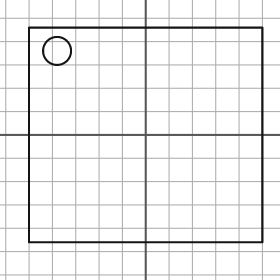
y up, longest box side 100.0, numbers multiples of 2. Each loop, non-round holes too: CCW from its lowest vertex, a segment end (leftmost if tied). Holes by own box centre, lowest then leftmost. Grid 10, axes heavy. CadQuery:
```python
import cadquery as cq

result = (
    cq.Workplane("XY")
    .moveTo(-50.0, -46.0)
    .lineTo(50.0, -46.0)
    .lineTo(50.0, 46.0)
    .lineTo(-50.0, 46.0)
    .close()
    .moveTo(-38.0, 36.0)
    .circle(6.0)
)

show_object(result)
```